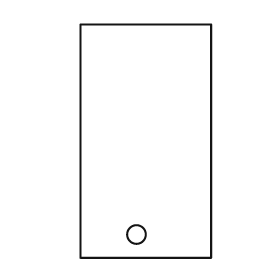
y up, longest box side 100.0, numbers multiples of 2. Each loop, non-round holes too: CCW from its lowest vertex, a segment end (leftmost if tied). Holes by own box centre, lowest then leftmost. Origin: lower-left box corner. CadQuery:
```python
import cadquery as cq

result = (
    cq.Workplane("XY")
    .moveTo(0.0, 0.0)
    .lineTo(56.0, 0.0)
    .lineTo(56.0, 100.0)
    .lineTo(0.0, 100.0)
    .close()
    .moveTo(24.0, 10.0)
    .circle(4.0)
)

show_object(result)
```